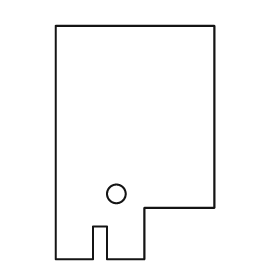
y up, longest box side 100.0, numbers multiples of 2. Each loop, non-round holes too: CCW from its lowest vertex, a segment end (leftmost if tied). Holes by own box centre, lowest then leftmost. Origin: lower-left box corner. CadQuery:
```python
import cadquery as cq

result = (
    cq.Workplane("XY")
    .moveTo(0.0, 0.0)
    .lineTo(16.0, 0.0)
    .lineTo(16.0, 14.0)
    .lineTo(22.0, 14.0)
    .lineTo(22.0, 0.0)
    .lineTo(38.0, 0.0)
    .lineTo(38.0, 22.0)
    .lineTo(68.0, 22.0)
    .lineTo(68.0, 100.0)
    .lineTo(0.0, 100.0)
    .close()
    .moveTo(26.0, 28.0)
    .circle(4.0)
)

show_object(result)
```